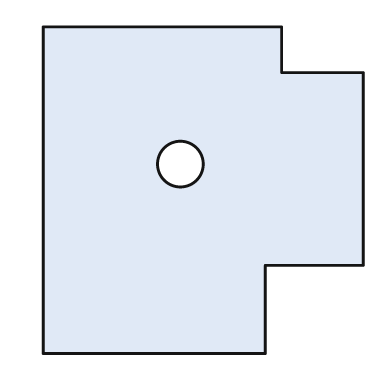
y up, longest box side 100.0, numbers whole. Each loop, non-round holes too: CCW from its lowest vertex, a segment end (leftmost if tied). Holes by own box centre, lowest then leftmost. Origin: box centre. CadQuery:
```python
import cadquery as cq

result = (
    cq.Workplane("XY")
    .moveTo(-49.0, -50.0)
    .lineTo(19.0, -50.0)
    .lineTo(19.0, -23.0)
    .lineTo(49.0, -23.0)
    .lineTo(49.0, 36.0)
    .lineTo(24.0, 36.0)
    .lineTo(24.0, 50.0)
    .lineTo(-49.0, 50.0)
    .close()
    .moveTo(-7.0, 8.0)
    .circle(7.0)
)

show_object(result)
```